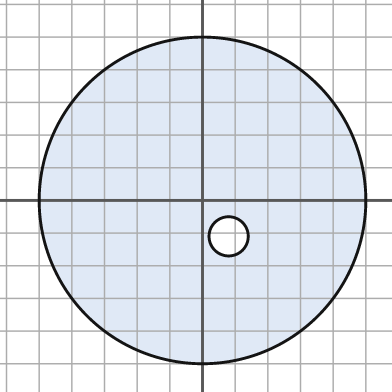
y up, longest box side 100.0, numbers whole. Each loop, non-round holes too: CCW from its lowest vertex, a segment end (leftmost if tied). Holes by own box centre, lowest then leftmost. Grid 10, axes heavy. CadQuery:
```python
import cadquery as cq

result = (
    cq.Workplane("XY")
    .moveTo(0.0, 0.0)
    .circle(50.0)
    .moveTo(8.0, -11.0)
    .circle(6.0)
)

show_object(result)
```